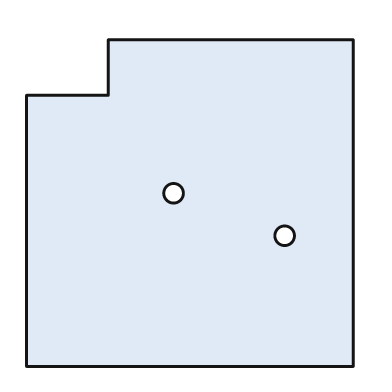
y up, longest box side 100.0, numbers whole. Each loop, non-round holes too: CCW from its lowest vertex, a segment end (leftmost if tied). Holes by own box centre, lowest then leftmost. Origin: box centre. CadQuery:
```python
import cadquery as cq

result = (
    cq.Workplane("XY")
    .moveTo(-50.0, -50.0)
    .lineTo(50.0, -50.0)
    .lineTo(50.0, 50.0)
    .lineTo(-25.0, 50.0)
    .lineTo(-25.0, 33.0)
    .lineTo(-50.0, 33.0)
    .close()
    .moveTo(29.0, -10.0)
    .circle(3.0)
    .moveTo(-5.0, 3.0)
    .circle(3.0)
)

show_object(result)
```